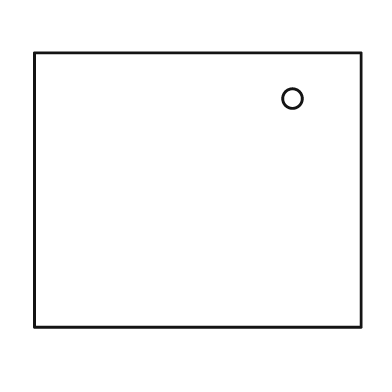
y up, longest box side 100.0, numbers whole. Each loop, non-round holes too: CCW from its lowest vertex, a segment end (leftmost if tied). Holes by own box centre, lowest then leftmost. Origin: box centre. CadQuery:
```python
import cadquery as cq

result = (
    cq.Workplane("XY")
    .moveTo(-50.0, -42.0)
    .lineTo(50.0, -42.0)
    .lineTo(50.0, 42.0)
    .lineTo(-50.0, 42.0)
    .close()
    .moveTo(29.0, 28.0)
    .circle(3.0)
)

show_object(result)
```